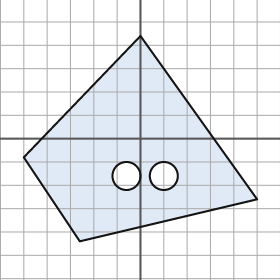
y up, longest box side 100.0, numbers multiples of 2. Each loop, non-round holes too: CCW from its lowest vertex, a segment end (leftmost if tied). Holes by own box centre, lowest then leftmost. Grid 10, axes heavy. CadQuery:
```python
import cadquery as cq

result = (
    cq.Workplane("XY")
    .moveTo(-26.0, -44.0)
    .lineTo(50.0, -26.0)
    .lineTo(0.0, 44.0)
    .lineTo(-50.0, -8.0)
    .close()
    .moveTo(-6.0, -16.0)
    .circle(6.0)
    .moveTo(10.0, -16.0)
    .circle(6.0)
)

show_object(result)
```